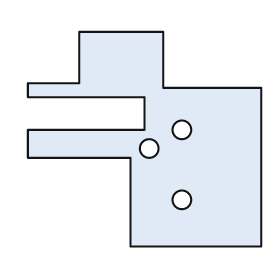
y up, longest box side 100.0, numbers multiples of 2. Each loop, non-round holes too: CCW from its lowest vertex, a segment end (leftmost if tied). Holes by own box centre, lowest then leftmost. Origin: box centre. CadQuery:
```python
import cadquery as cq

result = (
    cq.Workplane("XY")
    .moveTo(-6.0, -46.0)
    .lineTo(50.0, -46.0)
    .lineTo(50.0, 22.0)
    .lineTo(8.0, 22.0)
    .lineTo(8.0, 46.0)
    .lineTo(-28.0, 46.0)
    .lineTo(-28.0, 24.0)
    .lineTo(-50.0, 24.0)
    .lineTo(-50.0, 18.0)
    .lineTo(0.0, 18.0)
    .lineTo(0.0, 4.0)
    .lineTo(-50.0, 4.0)
    .lineTo(-50.0, -8.0)
    .lineTo(-6.0, -8.0)
    .close()
    .moveTo(16.0, -26.0)
    .circle(4.0)
    .moveTo(2.0, -4.0)
    .circle(4.0)
    .moveTo(16.0, 4.0)
    .circle(4.0)
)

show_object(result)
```